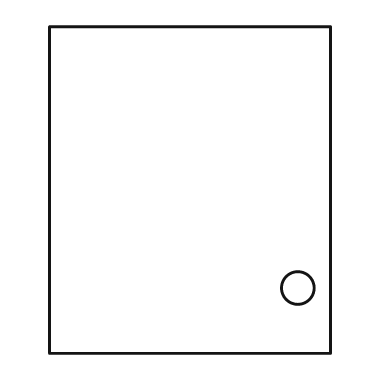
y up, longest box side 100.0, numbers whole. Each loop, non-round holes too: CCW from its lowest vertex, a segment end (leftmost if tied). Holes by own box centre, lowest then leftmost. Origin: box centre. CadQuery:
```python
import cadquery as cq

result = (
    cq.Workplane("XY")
    .moveTo(-43.0, -50.0)
    .lineTo(43.0, -50.0)
    .lineTo(43.0, 50.0)
    .lineTo(-43.0, 50.0)
    .close()
    .moveTo(33.0, -30.0)
    .circle(5.0)
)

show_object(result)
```